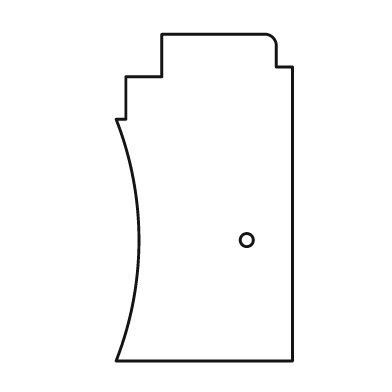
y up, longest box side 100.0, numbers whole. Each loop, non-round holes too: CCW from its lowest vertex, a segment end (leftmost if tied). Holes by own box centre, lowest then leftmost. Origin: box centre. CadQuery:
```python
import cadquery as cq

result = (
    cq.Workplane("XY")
    .moveTo(-27.0, -50.0)
    .lineTo(27.0, -50.0)
    .lineTo(27.0, 40.0)
    .lineTo(22.0, 40.0)
    .lineTo(22.0, 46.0)
    .threePointArc((21.0, 49.0), (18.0, 50.0))
    .lineTo(-13.0, 50.0)
    .lineTo(-13.0, 37.0)
    .lineTo(-24.0, 37.0)
    .lineTo(-24.0, 24.0)
    .lineTo(-27.0, 24.0)
    .threePointArc((-20.0, -13.0), (-27.0, -50.0))
    .close()
    .moveTo(13.0, -13.0)
    .circle(2.0)
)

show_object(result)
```